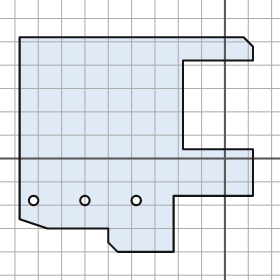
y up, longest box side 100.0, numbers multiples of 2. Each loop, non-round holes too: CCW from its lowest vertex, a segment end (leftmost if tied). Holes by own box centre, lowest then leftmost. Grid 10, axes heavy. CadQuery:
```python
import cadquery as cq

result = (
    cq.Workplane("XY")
    .moveTo(-46.0, -40.0)
    .lineTo(-22.0, -40.0)
    .lineTo(-22.0, -16.0)
    .lineTo(12.0, -16.0)
    .lineTo(12.0, 4.0)
    .lineTo(-18.0, 4.0)
    .lineTo(-18.0, 42.0)
    .lineTo(12.0, 42.0)
    .lineTo(12.0, 48.0)
    .lineTo(8.0, 52.0)
    .lineTo(-88.0, 52.0)
    .lineTo(-88.0, -26.0)
    .lineTo(-76.0, -30.0)
    .lineTo(-50.0, -30.0)
    .lineTo(-50.0, -36.0)
    .close()
    .moveTo(-82.0, -18.0)
    .circle(2.0)
    .moveTo(-60.0, -18.0)
    .circle(2.0)
    .moveTo(-38.0, -18.0)
    .circle(2.0)
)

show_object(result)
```